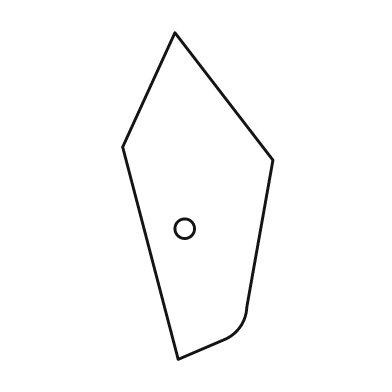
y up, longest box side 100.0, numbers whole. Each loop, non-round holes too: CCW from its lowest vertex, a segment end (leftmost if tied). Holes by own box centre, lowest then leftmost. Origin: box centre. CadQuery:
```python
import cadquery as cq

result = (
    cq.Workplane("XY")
    .moveTo(-6.0, -50.0)
    .lineTo(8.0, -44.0)
    .threePointArc((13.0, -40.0), (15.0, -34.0))
    .lineTo(23.0, 11.0)
    .lineTo(-7.0, 50.0)
    .lineTo(-23.0, 15.0)
    .close()
    .moveTo(-4.0, -10.0)
    .circle(3.0)
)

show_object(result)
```